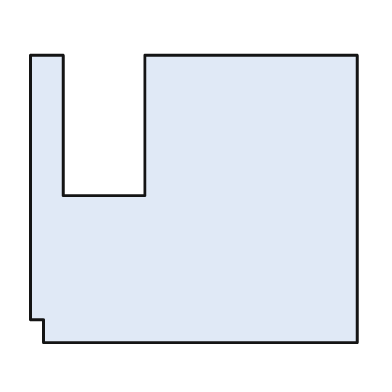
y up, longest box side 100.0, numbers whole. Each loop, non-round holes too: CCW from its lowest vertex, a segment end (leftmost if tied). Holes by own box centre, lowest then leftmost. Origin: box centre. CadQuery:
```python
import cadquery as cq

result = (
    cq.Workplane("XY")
    .moveTo(-46.0, -44.0)
    .lineTo(50.0, -44.0)
    .lineTo(50.0, 44.0)
    .lineTo(-15.0, 44.0)
    .lineTo(-15.0, 1.0)
    .lineTo(-40.0, 1.0)
    .lineTo(-40.0, 44.0)
    .lineTo(-50.0, 44.0)
    .lineTo(-50.0, -37.0)
    .lineTo(-46.0, -37.0)
    .close()
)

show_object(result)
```